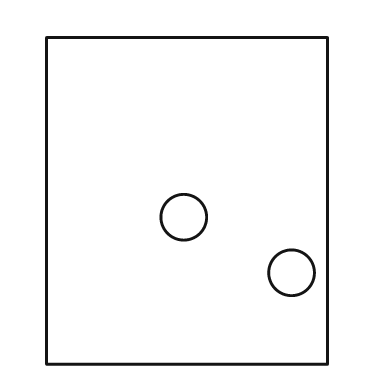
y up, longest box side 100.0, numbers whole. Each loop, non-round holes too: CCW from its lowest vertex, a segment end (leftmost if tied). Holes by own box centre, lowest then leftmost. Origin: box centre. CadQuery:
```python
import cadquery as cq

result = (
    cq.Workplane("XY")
    .moveTo(-43.0, -50.0)
    .lineTo(43.0, -50.0)
    .lineTo(43.0, 50.0)
    .lineTo(-43.0, 50.0)
    .close()
    .moveTo(32.0, -22.0)
    .circle(7.0)
    .moveTo(-1.0, -5.0)
    .circle(7.0)
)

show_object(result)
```